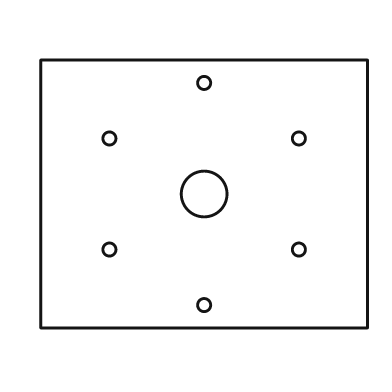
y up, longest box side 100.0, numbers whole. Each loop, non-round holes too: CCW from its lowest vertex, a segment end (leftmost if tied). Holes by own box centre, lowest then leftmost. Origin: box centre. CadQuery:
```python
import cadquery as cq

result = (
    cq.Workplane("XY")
    .moveTo(-50.0, -41.0)
    .lineTo(50.0, -41.0)
    .lineTo(50.0, 41.0)
    .lineTo(-50.0, 41.0)
    .close()
    .moveTo(0.0, -34.0)
    .circle(2.0)
    .moveTo(-29.0, -17.0)
    .circle(2.0)
    .moveTo(29.0, -17.0)
    .circle(2.0)
    .moveTo(0.0, 0.0)
    .circle(7.0)
    .moveTo(-29.0, 17.0)
    .circle(2.0)
    .moveTo(29.0, 17.0)
    .circle(2.0)
    .moveTo(0.0, 34.0)
    .circle(2.0)
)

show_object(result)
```